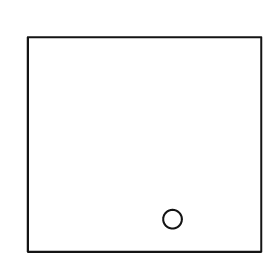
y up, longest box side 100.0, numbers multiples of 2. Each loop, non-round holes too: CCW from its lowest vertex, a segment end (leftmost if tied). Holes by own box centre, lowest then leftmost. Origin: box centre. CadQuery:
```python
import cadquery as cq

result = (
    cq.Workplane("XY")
    .moveTo(-50.0, -46.0)
    .lineTo(50.0, -46.0)
    .lineTo(50.0, 46.0)
    .lineTo(-50.0, 46.0)
    .close()
    .moveTo(12.0, -32.0)
    .circle(4.0)
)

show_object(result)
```